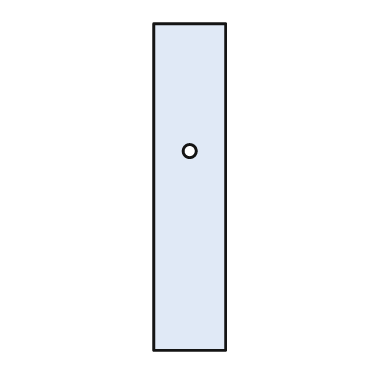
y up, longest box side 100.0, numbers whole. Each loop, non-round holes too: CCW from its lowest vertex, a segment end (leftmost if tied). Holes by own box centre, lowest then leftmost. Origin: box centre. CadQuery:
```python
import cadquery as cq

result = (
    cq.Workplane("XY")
    .moveTo(-11.0, -50.0)
    .lineTo(11.0, -50.0)
    .lineTo(11.0, 50.0)
    .lineTo(-11.0, 50.0)
    .close()
    .moveTo(0.0, 11.0)
    .circle(2.0)
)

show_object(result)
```